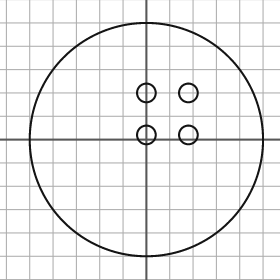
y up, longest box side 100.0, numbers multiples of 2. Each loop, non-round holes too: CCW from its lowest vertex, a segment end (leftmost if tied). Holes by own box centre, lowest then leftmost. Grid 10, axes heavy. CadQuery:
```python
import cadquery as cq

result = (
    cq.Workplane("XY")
    .moveTo(0.0, 0.0)
    .circle(50.0)
    .moveTo(0.0, 2.0)
    .circle(4.0)
    .moveTo(18.0, 2.0)
    .circle(4.0)
    .moveTo(0.0, 20.0)
    .circle(4.0)
    .moveTo(18.0, 20.0)
    .circle(4.0)
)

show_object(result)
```